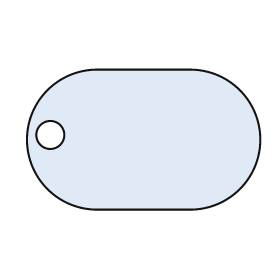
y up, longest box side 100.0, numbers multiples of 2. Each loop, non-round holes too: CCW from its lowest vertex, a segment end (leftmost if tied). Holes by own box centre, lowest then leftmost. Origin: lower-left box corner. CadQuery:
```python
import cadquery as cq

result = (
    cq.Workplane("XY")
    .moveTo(30.0, 0.0)
    .lineTo(70.0, 0.0)
    .threePointArc((100.0, 30.0), (70.0, 60.0))
    .lineTo(30.0, 60.0)
    .threePointArc((0.0, 30.0), (30.0, 0.0))
    .close()
    .moveTo(10.0, 32.0)
    .circle(6.0)
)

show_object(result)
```